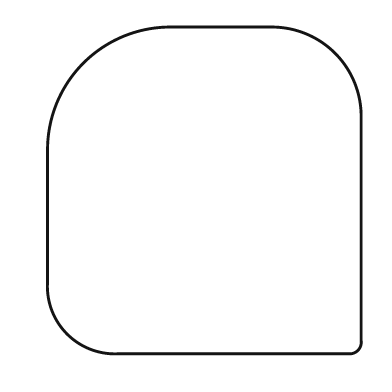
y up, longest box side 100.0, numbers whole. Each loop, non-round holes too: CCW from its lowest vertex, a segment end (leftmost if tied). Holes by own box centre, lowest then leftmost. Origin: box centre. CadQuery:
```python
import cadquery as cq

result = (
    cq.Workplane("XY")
    .moveTo(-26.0, -50.0)
    .lineTo(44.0, -50.0)
    .threePointArc((47.0, -49.0), (48.0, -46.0))
    .lineTo(48.0, 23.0)
    .threePointArc((40.0, 42.0), (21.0, 50.0))
    .lineTo(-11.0, 50.0)
    .threePointArc((-37.0, 39.0), (-48.0, 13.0))
    .lineTo(-48.0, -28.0)
    .threePointArc((-42.0, -44.0), (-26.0, -50.0))
    .close()
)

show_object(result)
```